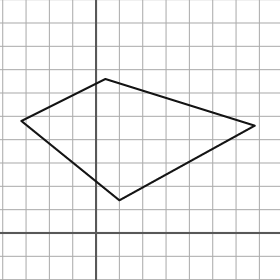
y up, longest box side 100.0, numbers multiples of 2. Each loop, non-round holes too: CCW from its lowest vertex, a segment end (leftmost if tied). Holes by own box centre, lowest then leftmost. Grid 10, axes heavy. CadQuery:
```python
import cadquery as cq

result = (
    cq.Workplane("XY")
    .moveTo(10.0, 14.0)
    .lineTo(68.0, 46.0)
    .lineTo(4.0, 66.0)
    .lineTo(-32.0, 48.0)
    .close()
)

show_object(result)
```